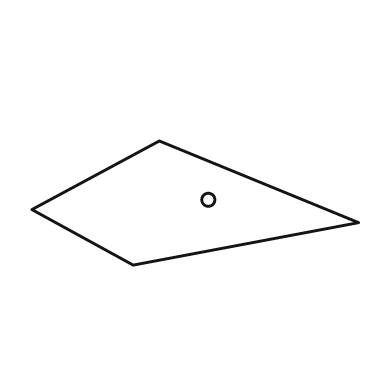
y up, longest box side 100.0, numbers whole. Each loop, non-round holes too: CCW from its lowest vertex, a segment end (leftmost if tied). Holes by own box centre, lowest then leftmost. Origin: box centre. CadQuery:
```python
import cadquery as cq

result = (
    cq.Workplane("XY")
    .moveTo(-19.0, -19.0)
    .lineTo(50.0, -6.0)
    .lineTo(-11.0, 19.0)
    .lineTo(-50.0, -2.0)
    .close()
    .moveTo(4.0, 1.0)
    .circle(2.0)
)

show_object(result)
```